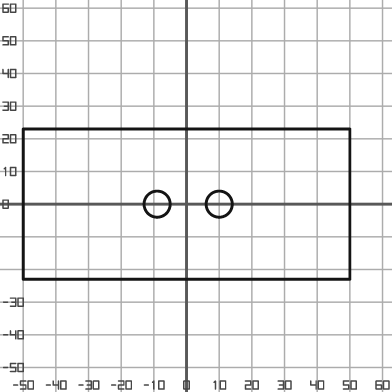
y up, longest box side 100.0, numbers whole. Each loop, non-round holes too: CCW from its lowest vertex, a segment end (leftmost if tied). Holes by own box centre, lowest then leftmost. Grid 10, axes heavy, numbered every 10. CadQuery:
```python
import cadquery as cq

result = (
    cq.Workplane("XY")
    .moveTo(-50.0, -23.0)
    .lineTo(50.0, -23.0)
    .lineTo(50.0, 23.0)
    .lineTo(-50.0, 23.0)
    .close()
    .moveTo(-9.0, 0.0)
    .circle(4.0)
    .moveTo(10.0, 0.0)
    .circle(4.0)
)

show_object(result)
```